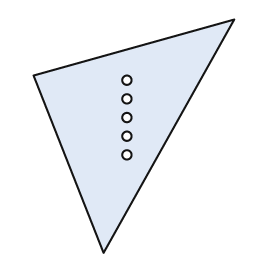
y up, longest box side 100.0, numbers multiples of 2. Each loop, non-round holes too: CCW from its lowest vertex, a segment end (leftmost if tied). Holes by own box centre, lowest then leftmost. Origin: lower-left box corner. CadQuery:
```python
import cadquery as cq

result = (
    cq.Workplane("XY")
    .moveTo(30.0, 0.0)
    .lineTo(86.0, 100.0)
    .lineTo(0.0, 76.0)
    .close()
    .moveTo(40.0, 42.0)
    .circle(2.0)
    .moveTo(40.0, 50.0)
    .circle(2.0)
    .moveTo(40.0, 58.0)
    .circle(2.0)
    .moveTo(40.0, 66.0)
    .circle(2.0)
    .moveTo(40.0, 74.0)
    .circle(2.0)
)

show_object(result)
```